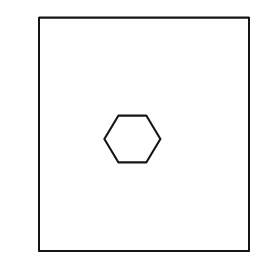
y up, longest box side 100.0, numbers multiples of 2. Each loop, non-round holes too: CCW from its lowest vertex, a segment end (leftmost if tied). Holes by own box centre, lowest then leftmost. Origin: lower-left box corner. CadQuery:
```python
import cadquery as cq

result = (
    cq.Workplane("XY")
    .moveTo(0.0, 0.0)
    .lineTo(90.0, 0.0)
    .lineTo(90.0, 100.0)
    .lineTo(0.0, 100.0)
    .close()
    .moveTo(34.0, 38.0)
    .lineTo(46.0, 38.0)
    .lineTo(52.0, 48.0)
    .lineTo(46.0, 58.0)
    .lineTo(34.0, 58.0)
    .lineTo(28.0, 48.0)
    .close()
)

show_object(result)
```